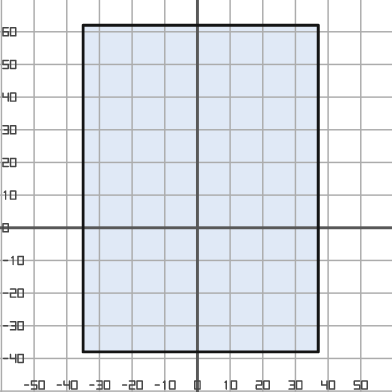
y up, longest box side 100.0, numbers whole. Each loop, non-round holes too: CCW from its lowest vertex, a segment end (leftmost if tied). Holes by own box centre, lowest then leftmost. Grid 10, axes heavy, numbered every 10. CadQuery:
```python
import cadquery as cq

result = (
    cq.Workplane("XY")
    .moveTo(-35.0, -38.0)
    .lineTo(37.0, -38.0)
    .lineTo(37.0, 62.0)
    .lineTo(-35.0, 62.0)
    .close()
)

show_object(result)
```